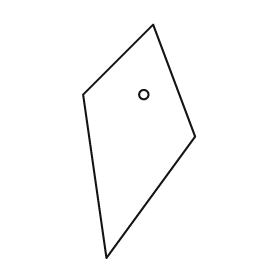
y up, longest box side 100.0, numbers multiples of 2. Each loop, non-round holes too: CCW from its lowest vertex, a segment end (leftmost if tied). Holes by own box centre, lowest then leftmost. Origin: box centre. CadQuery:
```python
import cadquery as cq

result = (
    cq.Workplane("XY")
    .moveTo(-14.0, -50.0)
    .lineTo(24.0, 2.0)
    .lineTo(6.0, 50.0)
    .lineTo(-24.0, 20.0)
    .close()
    .moveTo(2.0, 20.0)
    .circle(2.0)
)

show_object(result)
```